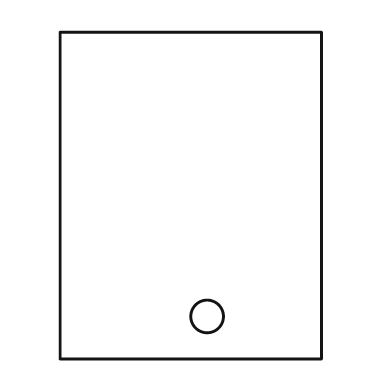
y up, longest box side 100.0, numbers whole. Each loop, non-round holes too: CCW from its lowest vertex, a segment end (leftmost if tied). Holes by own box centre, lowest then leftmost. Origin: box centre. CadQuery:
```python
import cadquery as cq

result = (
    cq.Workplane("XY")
    .moveTo(-40.0, -50.0)
    .lineTo(40.0, -50.0)
    .lineTo(40.0, 50.0)
    .lineTo(-40.0, 50.0)
    .close()
    .moveTo(5.0, -37.0)
    .circle(5.0)
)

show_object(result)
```